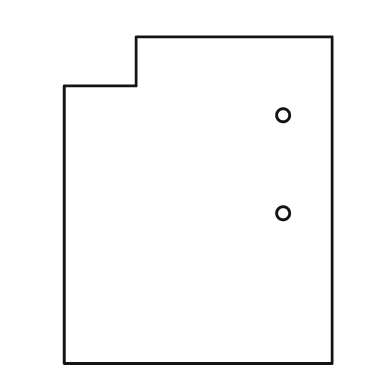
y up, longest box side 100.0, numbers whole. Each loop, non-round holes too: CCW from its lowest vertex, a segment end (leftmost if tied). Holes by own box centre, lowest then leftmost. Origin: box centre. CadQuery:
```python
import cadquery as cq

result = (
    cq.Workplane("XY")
    .moveTo(-41.0, -50.0)
    .lineTo(41.0, -50.0)
    .lineTo(41.0, 50.0)
    .lineTo(-19.0, 50.0)
    .lineTo(-19.0, 35.0)
    .lineTo(-41.0, 35.0)
    .close()
    .moveTo(26.0, -4.0)
    .circle(2.0)
    .moveTo(26.0, 26.0)
    .circle(2.0)
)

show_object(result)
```